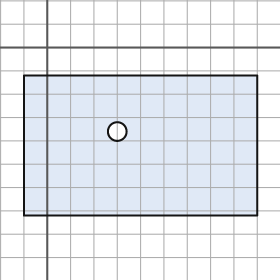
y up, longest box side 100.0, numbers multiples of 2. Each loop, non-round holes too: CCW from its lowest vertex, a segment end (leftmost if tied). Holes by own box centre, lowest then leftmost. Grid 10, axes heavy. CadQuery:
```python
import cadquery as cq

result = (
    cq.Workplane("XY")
    .moveTo(-10.0, -72.0)
    .lineTo(90.0, -72.0)
    .lineTo(90.0, -12.0)
    .lineTo(-10.0, -12.0)
    .close()
    .moveTo(30.0, -36.0)
    .circle(4.0)
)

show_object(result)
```